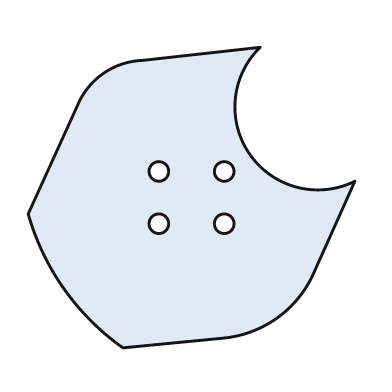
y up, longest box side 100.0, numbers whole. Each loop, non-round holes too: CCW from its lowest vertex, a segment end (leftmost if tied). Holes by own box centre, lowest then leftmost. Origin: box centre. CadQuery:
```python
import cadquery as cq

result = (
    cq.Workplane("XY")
    .moveTo(-21.0, -46.0)
    .lineTo(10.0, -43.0)
    .threePointArc((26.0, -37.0), (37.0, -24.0))
    .lineTo(50.0, 5.0)
    .threePointArc((18.0, 13.0), (21.0, 46.0))
    .lineTo(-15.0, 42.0)
    .threePointArc((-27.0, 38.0), (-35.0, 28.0))
    .lineTo(-50.0, -5.0)
    .threePointArc((-39.0, -28.0), (-21.0, -46.0))
    .close()
    .moveTo(-10.0, -8.0)
    .circle(3.0)
    .moveTo(10.0, -8.0)
    .circle(3.0)
    .moveTo(-10.0, 8.0)
    .circle(3.0)
    .moveTo(10.0, 8.0)
    .circle(3.0)
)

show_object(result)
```